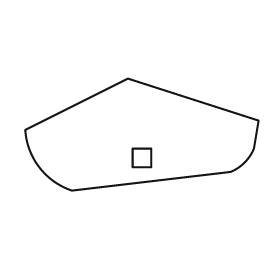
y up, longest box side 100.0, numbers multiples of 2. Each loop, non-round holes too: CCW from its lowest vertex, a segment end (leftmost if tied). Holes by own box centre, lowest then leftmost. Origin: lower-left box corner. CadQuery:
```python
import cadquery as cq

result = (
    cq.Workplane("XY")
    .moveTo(20.0, 0.0)
    .lineTo(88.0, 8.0)
    .threePointArc((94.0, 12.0), (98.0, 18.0))
    .lineTo(100.0, 30.0)
    .lineTo(44.0, 48.0)
    .lineTo(0.0, 26.0)
    .threePointArc((6.0, 10.0), (20.0, 0.0))
    .close()
    .moveTo(46.0, 10.0)
    .lineTo(54.0, 10.0)
    .lineTo(54.0, 18.0)
    .lineTo(46.0, 18.0)
    .close()
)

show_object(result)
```